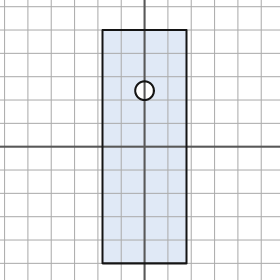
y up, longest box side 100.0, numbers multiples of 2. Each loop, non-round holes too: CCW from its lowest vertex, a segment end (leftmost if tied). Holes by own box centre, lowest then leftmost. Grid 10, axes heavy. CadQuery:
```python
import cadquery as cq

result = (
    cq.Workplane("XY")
    .moveTo(-18.0, -50.0)
    .lineTo(18.0, -50.0)
    .lineTo(18.0, 50.0)
    .lineTo(-18.0, 50.0)
    .close()
    .moveTo(0.0, 24.0)
    .circle(4.0)
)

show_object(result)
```